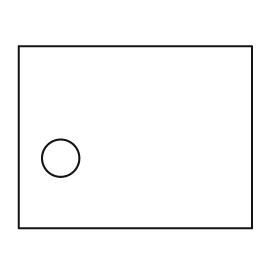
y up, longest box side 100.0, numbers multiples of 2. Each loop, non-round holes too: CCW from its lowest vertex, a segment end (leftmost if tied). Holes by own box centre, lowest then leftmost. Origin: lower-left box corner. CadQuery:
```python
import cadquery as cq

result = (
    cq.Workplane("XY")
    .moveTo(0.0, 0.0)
    .lineTo(100.0, 0.0)
    .lineTo(100.0, 78.0)
    .lineTo(0.0, 78.0)
    .close()
    .moveTo(18.0, 30.0)
    .circle(8.0)
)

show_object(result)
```